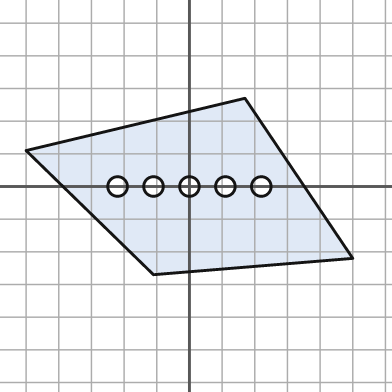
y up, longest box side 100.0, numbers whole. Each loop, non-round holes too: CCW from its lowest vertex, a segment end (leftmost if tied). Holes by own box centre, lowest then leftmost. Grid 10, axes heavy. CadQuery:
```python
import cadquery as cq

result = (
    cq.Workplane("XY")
    .moveTo(-11.0, -27.0)
    .lineTo(50.0, -22.0)
    .lineTo(17.0, 27.0)
    .lineTo(-50.0, 11.0)
    .close()
    .moveTo(-22.0, 0.0)
    .circle(3.0)
    .moveTo(-11.0, 0.0)
    .circle(3.0)
    .moveTo(0.0, 0.0)
    .circle(3.0)
    .moveTo(11.0, 0.0)
    .circle(3.0)
    .moveTo(22.0, 0.0)
    .circle(3.0)
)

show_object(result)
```